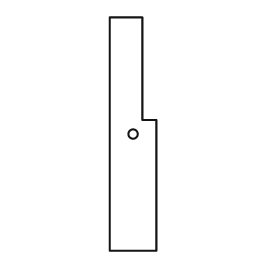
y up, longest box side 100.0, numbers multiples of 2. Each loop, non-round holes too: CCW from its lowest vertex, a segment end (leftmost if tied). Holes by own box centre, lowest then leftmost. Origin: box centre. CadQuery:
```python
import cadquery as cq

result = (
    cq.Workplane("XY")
    .moveTo(-10.0, -50.0)
    .lineTo(10.0, -50.0)
    .lineTo(10.0, 6.0)
    .lineTo(4.0, 6.0)
    .lineTo(4.0, 50.0)
    .lineTo(-10.0, 50.0)
    .close()
    .moveTo(0.0, 0.0)
    .circle(2.0)
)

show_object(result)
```